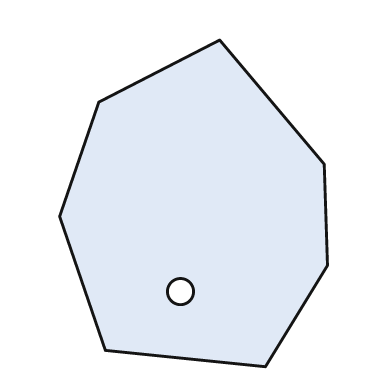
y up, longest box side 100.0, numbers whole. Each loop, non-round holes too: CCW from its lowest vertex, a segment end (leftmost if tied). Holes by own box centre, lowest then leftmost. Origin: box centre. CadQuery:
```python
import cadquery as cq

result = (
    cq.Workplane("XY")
    .moveTo(22.0, -50.0)
    .lineTo(41.0, -19.0)
    .lineTo(40.0, 12.0)
    .lineTo(8.0, 50.0)
    .lineTo(-29.0, 31.0)
    .lineTo(-41.0, -4.0)
    .lineTo(-27.0, -45.0)
    .close()
    .moveTo(-4.0, -27.0)
    .circle(4.0)
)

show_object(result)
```